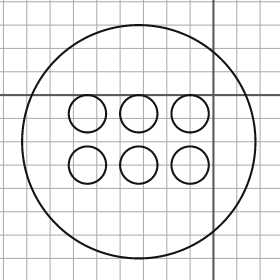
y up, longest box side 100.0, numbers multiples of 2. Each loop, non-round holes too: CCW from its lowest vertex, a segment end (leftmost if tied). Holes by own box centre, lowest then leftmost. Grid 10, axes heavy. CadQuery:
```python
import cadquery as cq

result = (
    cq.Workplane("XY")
    .moveTo(-32.0, -20.0)
    .circle(50.0)
    .moveTo(-54.0, -30.0)
    .circle(8.0)
    .moveTo(-32.0, -30.0)
    .circle(8.0)
    .moveTo(-10.0, -30.0)
    .circle(8.0)
    .moveTo(-54.0, -8.0)
    .circle(8.0)
    .moveTo(-32.0, -8.0)
    .circle(8.0)
    .moveTo(-10.0, -8.0)
    .circle(8.0)
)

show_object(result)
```